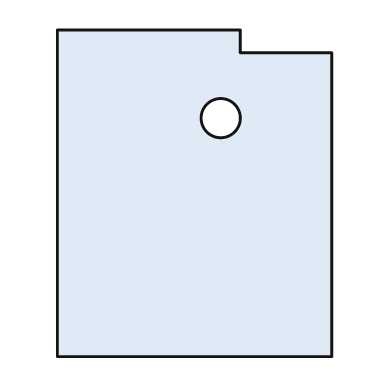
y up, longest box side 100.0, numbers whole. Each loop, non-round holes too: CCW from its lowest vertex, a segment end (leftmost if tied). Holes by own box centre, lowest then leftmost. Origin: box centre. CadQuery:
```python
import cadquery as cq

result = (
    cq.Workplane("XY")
    .moveTo(-42.0, -50.0)
    .lineTo(42.0, -50.0)
    .lineTo(42.0, 43.0)
    .lineTo(14.0, 43.0)
    .lineTo(14.0, 50.0)
    .lineTo(-42.0, 50.0)
    .close()
    .moveTo(8.0, 23.0)
    .circle(6.0)
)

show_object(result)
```